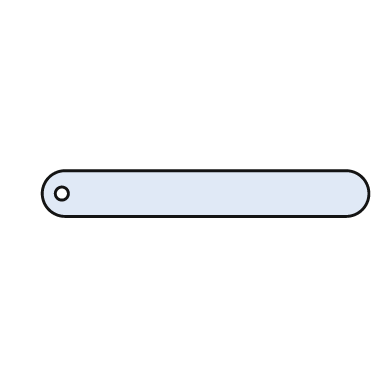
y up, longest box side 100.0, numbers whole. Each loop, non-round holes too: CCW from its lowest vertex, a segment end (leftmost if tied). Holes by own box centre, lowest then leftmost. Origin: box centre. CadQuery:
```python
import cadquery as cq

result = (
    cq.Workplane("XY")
    .moveTo(-43.0, -7.0)
    .lineTo(43.0, -7.0)
    .threePointArc((50.0, 0.0), (43.0, 7.0))
    .lineTo(-43.0, 7.0)
    .threePointArc((-50.0, 0.0), (-43.0, -7.0))
    .close()
    .moveTo(-44.0, 0.0)
    .circle(2.0)
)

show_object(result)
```